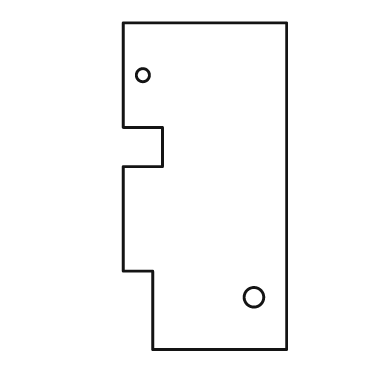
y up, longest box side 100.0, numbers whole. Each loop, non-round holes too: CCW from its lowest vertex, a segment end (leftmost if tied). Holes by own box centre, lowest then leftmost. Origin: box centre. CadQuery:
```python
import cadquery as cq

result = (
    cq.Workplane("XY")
    .moveTo(-16.0, -50.0)
    .lineTo(25.0, -50.0)
    .lineTo(25.0, 50.0)
    .lineTo(-25.0, 50.0)
    .lineTo(-25.0, 18.0)
    .lineTo(-13.0, 18.0)
    .lineTo(-13.0, 6.0)
    .lineTo(-25.0, 6.0)
    .lineTo(-25.0, -26.0)
    .lineTo(-16.0, -26.0)
    .close()
    .moveTo(15.0, -34.0)
    .circle(3.0)
    .moveTo(-19.0, 34.0)
    .circle(2.0)
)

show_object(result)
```